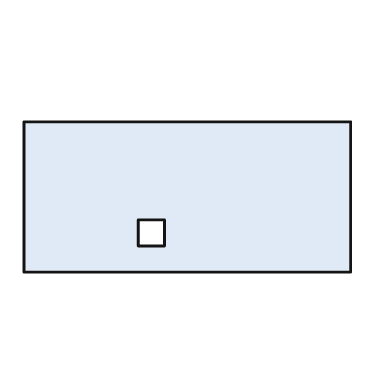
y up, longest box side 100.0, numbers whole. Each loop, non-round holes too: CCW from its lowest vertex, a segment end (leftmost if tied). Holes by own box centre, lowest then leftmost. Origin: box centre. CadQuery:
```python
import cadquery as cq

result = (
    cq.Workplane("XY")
    .moveTo(-50.0, -23.0)
    .lineTo(50.0, -23.0)
    .lineTo(50.0, 23.0)
    .lineTo(-50.0, 23.0)
    .close()
    .moveTo(-15.0, -15.0)
    .lineTo(-7.0, -15.0)
    .lineTo(-7.0, -7.0)
    .lineTo(-15.0, -7.0)
    .close()
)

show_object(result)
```